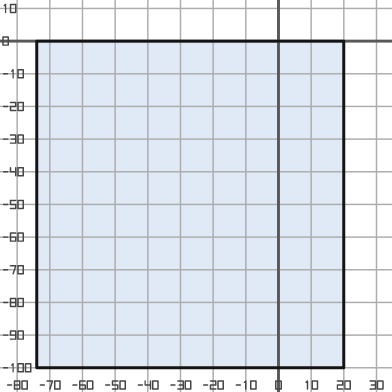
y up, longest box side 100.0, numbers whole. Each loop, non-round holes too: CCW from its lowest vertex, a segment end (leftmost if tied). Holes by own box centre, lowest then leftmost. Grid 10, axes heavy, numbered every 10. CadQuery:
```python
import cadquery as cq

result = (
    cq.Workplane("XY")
    .moveTo(-74.0, -100.0)
    .lineTo(20.0, -100.0)
    .lineTo(20.0, 0.0)
    .lineTo(-74.0, 0.0)
    .close()
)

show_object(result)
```